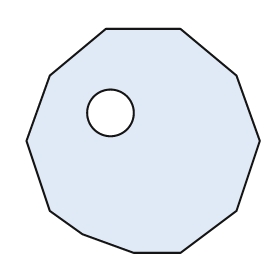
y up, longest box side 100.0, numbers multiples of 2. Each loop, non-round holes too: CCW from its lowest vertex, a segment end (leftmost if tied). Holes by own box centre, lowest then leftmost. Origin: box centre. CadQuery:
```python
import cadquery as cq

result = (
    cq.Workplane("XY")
    .moveTo(-4.0, -48.0)
    .lineTo(16.0, -48.0)
    .lineTo(40.0, -30.0)
    .lineTo(50.0, 0.0)
    .lineTo(40.0, 28.0)
    .lineTo(16.0, 48.0)
    .lineTo(-16.0, 48.0)
    .lineTo(-40.0, 28.0)
    .lineTo(-50.0, 0.0)
    .lineTo(-40.0, -30.0)
    .lineTo(-26.0, -40.0)
    .close()
    .moveTo(-14.0, 12.0)
    .circle(10.0)
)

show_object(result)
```